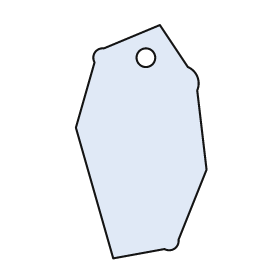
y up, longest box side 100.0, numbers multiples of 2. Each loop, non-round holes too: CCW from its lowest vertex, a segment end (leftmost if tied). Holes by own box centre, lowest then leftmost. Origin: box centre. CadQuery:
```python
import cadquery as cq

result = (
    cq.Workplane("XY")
    .moveTo(-12.0, -50.0)
    .lineTo(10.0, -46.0)
    .threePointArc((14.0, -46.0), (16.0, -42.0))
    .lineTo(28.0, -12.0)
    .lineTo(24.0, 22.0)
    .threePointArc((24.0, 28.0), (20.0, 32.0))
    .lineTo(8.0, 50.0)
    .lineTo(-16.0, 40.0)
    .threePointArc((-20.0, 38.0), (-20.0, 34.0))
    .lineTo(-28.0, 6.0)
    .close()
    .moveTo(2.0, 36.0)
    .circle(4.0)
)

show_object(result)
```